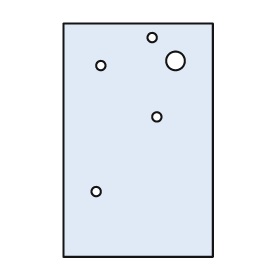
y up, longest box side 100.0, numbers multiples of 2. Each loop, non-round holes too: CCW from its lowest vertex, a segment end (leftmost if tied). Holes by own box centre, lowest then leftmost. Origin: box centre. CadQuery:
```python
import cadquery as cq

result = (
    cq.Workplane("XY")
    .moveTo(-32.0, -50.0)
    .lineTo(32.0, -50.0)
    .lineTo(32.0, 50.0)
    .lineTo(-32.0, 50.0)
    .close()
    .moveTo(-18.0, -22.0)
    .circle(2.0)
    .moveTo(8.0, 10.0)
    .circle(2.0)
    .moveTo(-16.0, 32.0)
    .circle(2.0)
    .moveTo(16.0, 34.0)
    .circle(4.0)
    .moveTo(6.0, 44.0)
    .circle(2.0)
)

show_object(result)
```